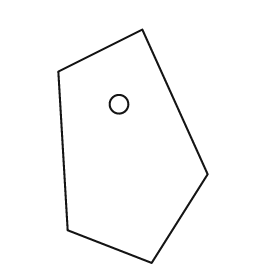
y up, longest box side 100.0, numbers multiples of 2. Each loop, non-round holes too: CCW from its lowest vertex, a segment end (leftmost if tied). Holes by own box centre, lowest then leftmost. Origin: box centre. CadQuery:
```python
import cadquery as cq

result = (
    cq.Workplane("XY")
    .moveTo(8.0, -50.0)
    .lineTo(32.0, -12.0)
    .lineTo(4.0, 50.0)
    .lineTo(-32.0, 32.0)
    .lineTo(-28.0, -36.0)
    .close()
    .moveTo(-6.0, 18.0)
    .circle(4.0)
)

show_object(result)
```